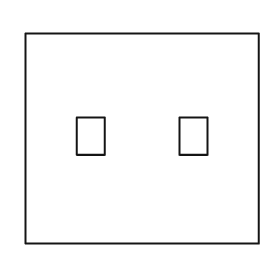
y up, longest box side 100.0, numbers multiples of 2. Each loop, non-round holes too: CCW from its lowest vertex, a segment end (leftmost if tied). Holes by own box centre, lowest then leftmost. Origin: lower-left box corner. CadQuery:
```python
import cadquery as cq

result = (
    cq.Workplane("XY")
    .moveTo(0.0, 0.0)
    .lineTo(100.0, 0.0)
    .lineTo(100.0, 90.0)
    .lineTo(0.0, 90.0)
    .close()
    .moveTo(22.0, 38.0)
    .lineTo(34.0, 38.0)
    .lineTo(34.0, 54.0)
    .lineTo(22.0, 54.0)
    .close()
    .moveTo(66.0, 38.0)
    .lineTo(78.0, 38.0)
    .lineTo(78.0, 54.0)
    .lineTo(66.0, 54.0)
    .close()
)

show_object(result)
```